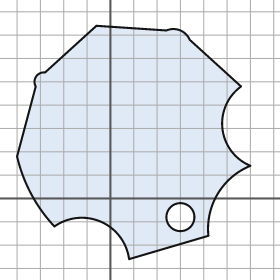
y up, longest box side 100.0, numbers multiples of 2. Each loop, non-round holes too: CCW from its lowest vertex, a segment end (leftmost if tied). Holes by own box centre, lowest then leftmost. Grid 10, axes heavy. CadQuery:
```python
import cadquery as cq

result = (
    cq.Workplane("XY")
    .moveTo(8.0, -26.0)
    .lineTo(42.0, -16.0)
    .threePointArc((46.0, 2.0), (60.0, 14.0))
    .threePointArc((48.0, 30.0), (56.0, 48.0))
    .lineTo(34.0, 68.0)
    .threePointArc((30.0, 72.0), (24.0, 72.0))
    .lineTo(-6.0, 74.0)
    .lineTo(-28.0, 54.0)
    .threePointArc((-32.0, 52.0), (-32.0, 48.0))
    .lineTo(-40.0, 18.0)
    .threePointArc((-34.0, 2.0), (-24.0, -12.0))
    .threePointArc((-4.0, -10.0), (8.0, -26.0))
    .close()
    .moveTo(30.0, -8.0)
    .circle(6.0)
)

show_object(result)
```